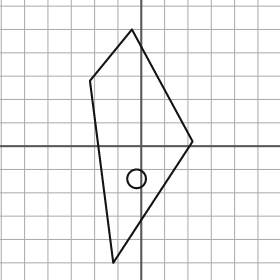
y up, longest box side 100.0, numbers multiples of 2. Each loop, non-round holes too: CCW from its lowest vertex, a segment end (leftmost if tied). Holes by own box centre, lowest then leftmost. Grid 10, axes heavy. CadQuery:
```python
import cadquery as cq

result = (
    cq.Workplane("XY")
    .moveTo(-12.0, -50.0)
    .lineTo(22.0, 2.0)
    .lineTo(-4.0, 50.0)
    .lineTo(-22.0, 28.0)
    .close()
    .moveTo(-2.0, -14.0)
    .circle(4.0)
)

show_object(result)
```